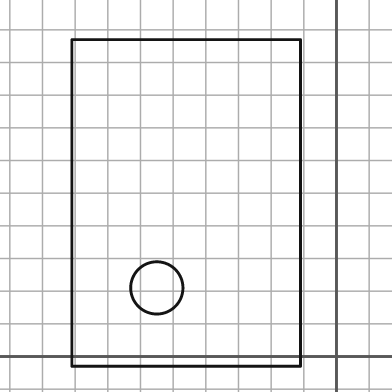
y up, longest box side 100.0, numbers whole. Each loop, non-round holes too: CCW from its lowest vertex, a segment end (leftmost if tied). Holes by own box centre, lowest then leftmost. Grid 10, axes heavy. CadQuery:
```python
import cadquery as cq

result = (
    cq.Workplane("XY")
    .moveTo(-81.0, -3.0)
    .lineTo(-11.0, -3.0)
    .lineTo(-11.0, 97.0)
    .lineTo(-81.0, 97.0)
    .close()
    .moveTo(-55.0, 21.0)
    .circle(8.0)
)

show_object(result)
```